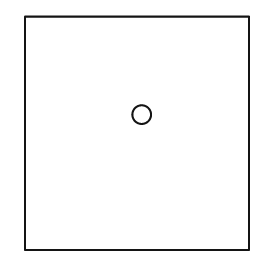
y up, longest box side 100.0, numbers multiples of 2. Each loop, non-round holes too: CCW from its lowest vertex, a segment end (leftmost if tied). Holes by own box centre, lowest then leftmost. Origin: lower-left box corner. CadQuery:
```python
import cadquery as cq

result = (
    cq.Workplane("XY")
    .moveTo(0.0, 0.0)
    .lineTo(96.0, 0.0)
    .lineTo(96.0, 100.0)
    .lineTo(0.0, 100.0)
    .close()
    .moveTo(50.0, 58.0)
    .circle(4.0)
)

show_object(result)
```